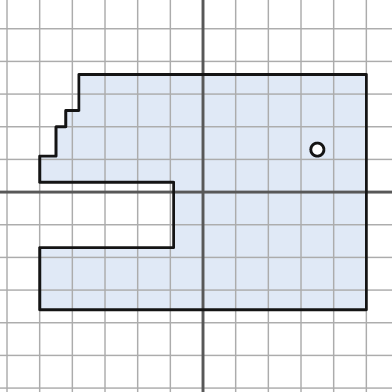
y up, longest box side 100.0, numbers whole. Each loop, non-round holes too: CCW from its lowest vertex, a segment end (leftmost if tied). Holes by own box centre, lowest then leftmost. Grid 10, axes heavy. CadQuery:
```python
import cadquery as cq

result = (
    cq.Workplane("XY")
    .moveTo(-50.0, -36.0)
    .lineTo(50.0, -36.0)
    .lineTo(50.0, 36.0)
    .lineTo(-38.0, 36.0)
    .lineTo(-38.0, 25.0)
    .lineTo(-42.0, 25.0)
    .lineTo(-42.0, 20.0)
    .lineTo(-45.0, 20.0)
    .lineTo(-45.0, 11.0)
    .lineTo(-50.0, 11.0)
    .lineTo(-50.0, 3.0)
    .lineTo(-9.0, 3.0)
    .lineTo(-9.0, -17.0)
    .lineTo(-50.0, -17.0)
    .close()
    .moveTo(35.0, 13.0)
    .circle(2.0)
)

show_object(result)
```